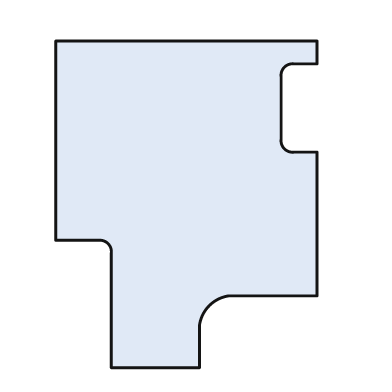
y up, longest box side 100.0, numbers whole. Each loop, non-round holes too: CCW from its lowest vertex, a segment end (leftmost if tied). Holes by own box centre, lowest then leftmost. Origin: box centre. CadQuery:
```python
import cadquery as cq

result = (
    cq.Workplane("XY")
    .moveTo(-23.0, -50.0)
    .lineTo(4.0, -50.0)
    .lineTo(4.0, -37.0)
    .threePointArc((7.0, -31.0), (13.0, -28.0))
    .lineTo(40.0, -28.0)
    .lineTo(40.0, 16.0)
    .lineTo(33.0, 16.0)
    .threePointArc((30.0, 17.0), (29.0, 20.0))
    .lineTo(29.0, 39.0)
    .threePointArc((30.0, 42.0), (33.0, 43.0))
    .lineTo(40.0, 43.0)
    .lineTo(40.0, 50.0)
    .lineTo(-40.0, 50.0)
    .lineTo(-40.0, -11.0)
    .lineTo(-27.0, -11.0)
    .threePointArc((-24.0, -12.0), (-23.0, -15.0))
    .close()
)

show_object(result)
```